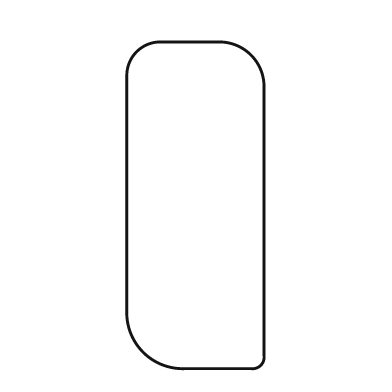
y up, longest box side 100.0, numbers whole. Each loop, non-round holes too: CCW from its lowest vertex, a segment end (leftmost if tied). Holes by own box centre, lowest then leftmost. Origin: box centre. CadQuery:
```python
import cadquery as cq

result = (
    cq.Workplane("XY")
    .moveTo(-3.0, -50.0)
    .lineTo(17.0, -50.0)
    .threePointArc((20.0, -49.0), (21.0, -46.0))
    .lineTo(21.0, 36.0)
    .threePointArc((17.0, 46.0), (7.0, 50.0))
    .lineTo(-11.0, 50.0)
    .threePointArc((-18.0, 47.0), (-21.0, 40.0))
    .lineTo(-21.0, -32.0)
    .threePointArc((-16.0, -45.0), (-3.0, -50.0))
    .close()
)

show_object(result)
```